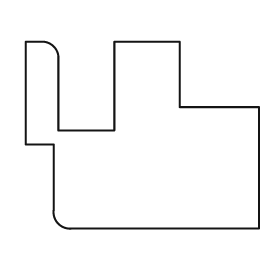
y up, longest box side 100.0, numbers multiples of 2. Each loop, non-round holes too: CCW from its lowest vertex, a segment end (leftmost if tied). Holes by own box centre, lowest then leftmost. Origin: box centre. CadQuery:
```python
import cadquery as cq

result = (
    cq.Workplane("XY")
    .moveTo(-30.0, -40.0)
    .lineTo(50.0, -40.0)
    .lineTo(50.0, 12.0)
    .lineTo(16.0, 12.0)
    .lineTo(16.0, 40.0)
    .lineTo(-12.0, 40.0)
    .lineTo(-12.0, 2.0)
    .lineTo(-36.0, 2.0)
    .lineTo(-36.0, 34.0)
    .threePointArc((-38.0, 38.0), (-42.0, 40.0))
    .lineTo(-50.0, 40.0)
    .lineTo(-50.0, -4.0)
    .lineTo(-38.0, -4.0)
    .lineTo(-38.0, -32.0)
    .threePointArc((-36.0, -38.0), (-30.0, -40.0))
    .close()
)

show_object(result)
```